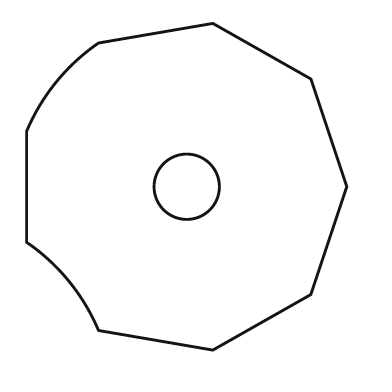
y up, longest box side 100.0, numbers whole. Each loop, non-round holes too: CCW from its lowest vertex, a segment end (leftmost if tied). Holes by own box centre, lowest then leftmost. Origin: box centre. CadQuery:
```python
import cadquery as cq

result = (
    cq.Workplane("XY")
    .moveTo(8.0, -50.0)
    .lineTo(38.0, -33.0)
    .lineTo(49.0, 0.0)
    .lineTo(38.0, 33.0)
    .lineTo(8.0, 50.0)
    .lineTo(-27.0, 44.0)
    .threePointArc((-40.0, 32.0), (-49.0, 17.0))
    .lineTo(-49.0, -17.0)
    .threePointArc((-36.0, -29.0), (-27.0, -44.0))
    .close()
    .moveTo(0.0, 0.0)
    .circle(10.0)
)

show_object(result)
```